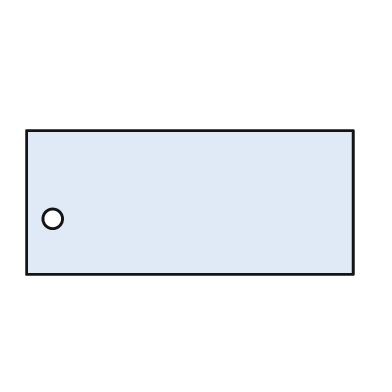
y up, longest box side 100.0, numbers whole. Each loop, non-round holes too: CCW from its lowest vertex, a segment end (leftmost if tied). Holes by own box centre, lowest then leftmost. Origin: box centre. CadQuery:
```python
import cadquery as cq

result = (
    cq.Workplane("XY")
    .moveTo(-50.0, -22.0)
    .lineTo(50.0, -22.0)
    .lineTo(50.0, 22.0)
    .lineTo(-50.0, 22.0)
    .close()
    .moveTo(-42.0, -5.0)
    .circle(3.0)
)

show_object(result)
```